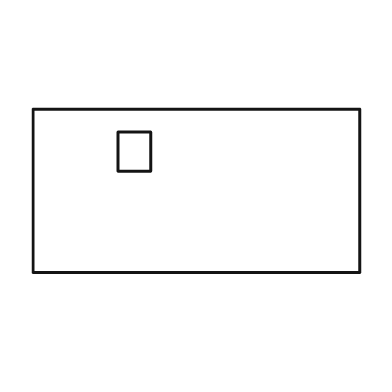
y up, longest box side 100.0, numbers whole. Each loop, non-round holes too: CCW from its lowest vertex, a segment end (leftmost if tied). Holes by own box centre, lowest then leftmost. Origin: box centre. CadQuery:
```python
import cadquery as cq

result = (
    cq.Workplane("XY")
    .moveTo(-50.0, -25.0)
    .lineTo(50.0, -25.0)
    .lineTo(50.0, 25.0)
    .lineTo(-50.0, 25.0)
    .close()
    .moveTo(-24.0, 6.0)
    .lineTo(-14.0, 6.0)
    .lineTo(-14.0, 18.0)
    .lineTo(-24.0, 18.0)
    .close()
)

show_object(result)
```